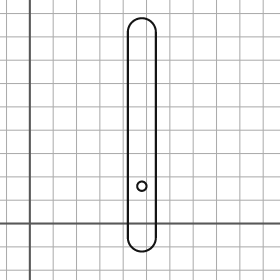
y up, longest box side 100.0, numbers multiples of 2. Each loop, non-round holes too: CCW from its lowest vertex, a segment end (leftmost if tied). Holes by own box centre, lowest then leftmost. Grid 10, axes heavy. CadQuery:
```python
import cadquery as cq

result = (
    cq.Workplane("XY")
    .moveTo(42.0, -6.0)
    .threePointArc((48.0, -12.0), (54.0, -6.0))
    .lineTo(54.0, 82.0)
    .threePointArc((48.0, 88.0), (42.0, 82.0))
    .close()
    .moveTo(48.0, 16.0)
    .circle(2.0)
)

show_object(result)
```